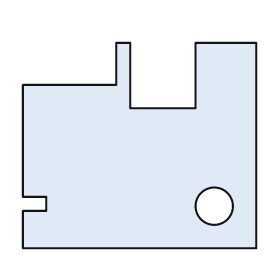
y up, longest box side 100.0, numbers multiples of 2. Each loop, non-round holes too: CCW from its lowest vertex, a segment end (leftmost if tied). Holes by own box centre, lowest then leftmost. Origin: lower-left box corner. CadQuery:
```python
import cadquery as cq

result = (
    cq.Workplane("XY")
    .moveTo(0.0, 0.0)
    .lineTo(100.0, 0.0)
    .lineTo(100.0, 88.0)
    .lineTo(74.0, 88.0)
    .lineTo(74.0, 60.0)
    .lineTo(46.0, 60.0)
    .lineTo(46.0, 88.0)
    .lineTo(40.0, 88.0)
    .lineTo(40.0, 70.0)
    .lineTo(0.0, 70.0)
    .lineTo(0.0, 22.0)
    .lineTo(10.0, 22.0)
    .lineTo(10.0, 16.0)
    .lineTo(0.0, 16.0)
    .close()
    .moveTo(82.0, 18.0)
    .circle(8.0)
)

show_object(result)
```